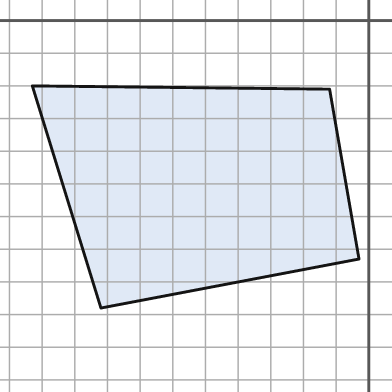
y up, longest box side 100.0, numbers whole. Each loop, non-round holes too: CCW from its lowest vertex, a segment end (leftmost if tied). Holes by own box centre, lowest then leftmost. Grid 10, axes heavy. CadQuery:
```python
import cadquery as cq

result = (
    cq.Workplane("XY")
    .moveTo(-82.0, -88.0)
    .lineTo(-3.0, -73.0)
    .lineTo(-12.0, -21.0)
    .lineTo(-103.0, -20.0)
    .close()
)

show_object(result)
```